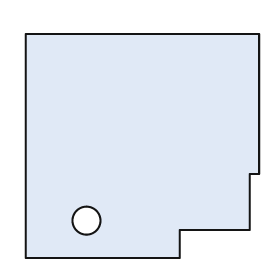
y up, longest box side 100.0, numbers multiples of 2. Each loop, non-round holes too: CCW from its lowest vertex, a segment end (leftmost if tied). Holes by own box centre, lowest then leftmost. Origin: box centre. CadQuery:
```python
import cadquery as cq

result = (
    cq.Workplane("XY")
    .moveTo(-50.0, -48.0)
    .lineTo(16.0, -48.0)
    .lineTo(16.0, -36.0)
    .lineTo(46.0, -36.0)
    .lineTo(46.0, -12.0)
    .lineTo(50.0, -12.0)
    .lineTo(50.0, 48.0)
    .lineTo(-50.0, 48.0)
    .close()
    .moveTo(-24.0, -32.0)
    .circle(6.0)
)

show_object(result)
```